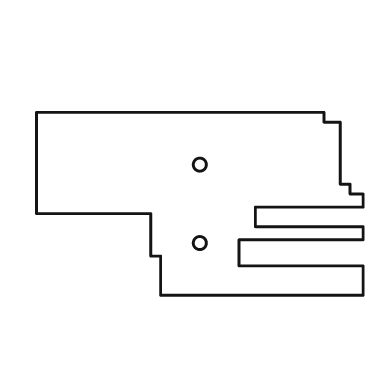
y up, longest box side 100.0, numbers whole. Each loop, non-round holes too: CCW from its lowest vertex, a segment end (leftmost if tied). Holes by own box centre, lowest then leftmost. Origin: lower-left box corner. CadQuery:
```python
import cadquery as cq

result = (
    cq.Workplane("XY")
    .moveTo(38.0, 0.0)
    .lineTo(100.0, 0.0)
    .lineTo(100.0, 9.0)
    .lineTo(62.0, 9.0)
    .lineTo(62.0, 17.0)
    .lineTo(100.0, 17.0)
    .lineTo(100.0, 21.0)
    .lineTo(67.0, 21.0)
    .lineTo(67.0, 27.0)
    .lineTo(100.0, 27.0)
    .lineTo(100.0, 31.0)
    .lineTo(96.0, 31.0)
    .lineTo(96.0, 34.0)
    .lineTo(93.0, 34.0)
    .lineTo(93.0, 53.0)
    .lineTo(88.0, 53.0)
    .lineTo(88.0, 56.0)
    .lineTo(0.0, 56.0)
    .lineTo(0.0, 25.0)
    .lineTo(35.0, 25.0)
    .lineTo(35.0, 12.0)
    .lineTo(38.0, 12.0)
    .close()
    .moveTo(50.0, 16.0)
    .circle(2.0)
    .moveTo(50.0, 40.0)
    .circle(2.0)
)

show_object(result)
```